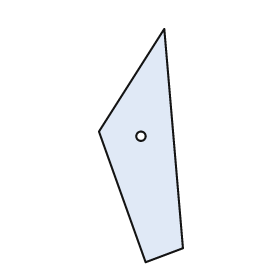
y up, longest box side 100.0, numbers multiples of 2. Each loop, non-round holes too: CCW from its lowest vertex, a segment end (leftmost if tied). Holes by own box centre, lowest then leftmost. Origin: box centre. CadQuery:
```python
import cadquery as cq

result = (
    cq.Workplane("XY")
    .moveTo(2.0, -50.0)
    .lineTo(18.0, -44.0)
    .lineTo(10.0, 50.0)
    .lineTo(-18.0, 6.0)
    .close()
    .moveTo(0.0, 4.0)
    .circle(2.0)
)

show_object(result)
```